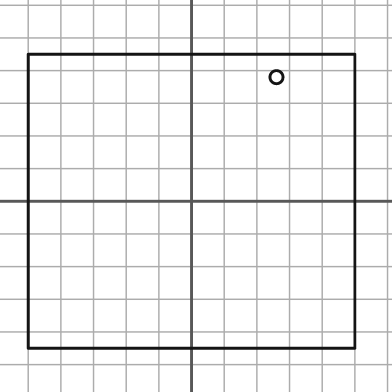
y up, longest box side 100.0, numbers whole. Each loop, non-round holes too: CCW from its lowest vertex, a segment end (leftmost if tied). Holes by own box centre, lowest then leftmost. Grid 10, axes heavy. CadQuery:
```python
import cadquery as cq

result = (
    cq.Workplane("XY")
    .moveTo(-50.0, -45.0)
    .lineTo(50.0, -45.0)
    .lineTo(50.0, 45.0)
    .lineTo(-50.0, 45.0)
    .close()
    .moveTo(26.0, 38.0)
    .circle(2.0)
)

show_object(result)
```